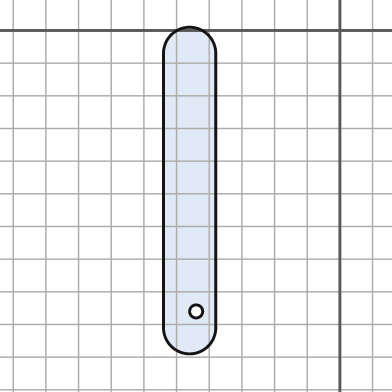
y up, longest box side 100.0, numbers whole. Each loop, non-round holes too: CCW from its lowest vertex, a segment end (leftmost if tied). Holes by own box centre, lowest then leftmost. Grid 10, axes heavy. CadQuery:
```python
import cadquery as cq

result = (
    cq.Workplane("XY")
    .moveTo(-54.0, -91.0)
    .threePointArc((-46.0, -99.0), (-38.0, -91.0))
    .lineTo(-38.0, -7.0)
    .threePointArc((-46.0, 1.0), (-54.0, -7.0))
    .close()
    .moveTo(-44.0, -86.0)
    .circle(2.0)
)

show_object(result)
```